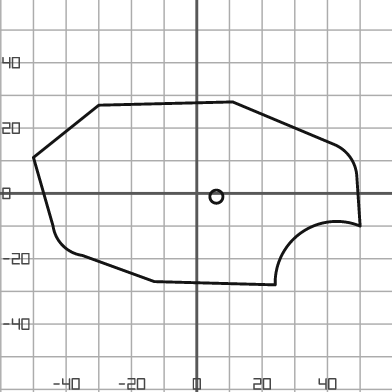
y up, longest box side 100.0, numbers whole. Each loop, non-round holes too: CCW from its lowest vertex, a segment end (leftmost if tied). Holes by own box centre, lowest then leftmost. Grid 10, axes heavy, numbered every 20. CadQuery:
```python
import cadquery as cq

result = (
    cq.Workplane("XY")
    .moveTo(24.0, -28.0)
    .threePointArc((32.0, -12.0), (50.0, -10.0))
    .lineTo(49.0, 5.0)
    .threePointArc((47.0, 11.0), (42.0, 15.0))
    .lineTo(11.0, 28.0)
    .lineTo(-30.0, 27.0)
    .lineTo(-50.0, 11.0)
    .lineTo(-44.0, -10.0)
    .threePointArc((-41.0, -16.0), (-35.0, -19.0))
    .lineTo(-13.0, -27.0)
    .close()
    .moveTo(6.0, -1.0)
    .circle(2.0)
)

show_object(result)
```